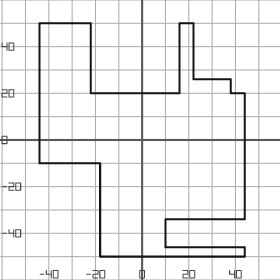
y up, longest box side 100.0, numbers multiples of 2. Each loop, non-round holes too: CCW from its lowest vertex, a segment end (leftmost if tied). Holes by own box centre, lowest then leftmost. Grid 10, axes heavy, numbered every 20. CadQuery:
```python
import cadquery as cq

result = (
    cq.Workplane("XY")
    .moveTo(-18.0, -50.0)
    .lineTo(44.0, -50.0)
    .lineTo(44.0, -46.0)
    .lineTo(10.0, -46.0)
    .lineTo(10.0, -34.0)
    .lineTo(44.0, -34.0)
    .lineTo(44.0, 20.0)
    .lineTo(38.0, 20.0)
    .lineTo(38.0, 26.0)
    .lineTo(22.0, 26.0)
    .lineTo(22.0, 50.0)
    .lineTo(16.0, 50.0)
    .lineTo(16.0, 20.0)
    .lineTo(-22.0, 20.0)
    .lineTo(-22.0, 50.0)
    .lineTo(-44.0, 50.0)
    .lineTo(-44.0, -10.0)
    .lineTo(-18.0, -10.0)
    .close()
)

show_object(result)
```